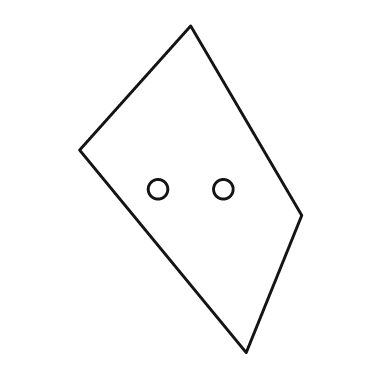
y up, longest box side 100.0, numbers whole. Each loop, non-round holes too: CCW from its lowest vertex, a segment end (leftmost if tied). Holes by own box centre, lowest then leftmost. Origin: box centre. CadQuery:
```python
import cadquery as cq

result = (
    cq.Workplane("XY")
    .moveTo(17.0, -50.0)
    .lineTo(34.0, -8.0)
    .lineTo(0.0, 50.0)
    .lineTo(-34.0, 12.0)
    .close()
    .moveTo(-10.0, 0.0)
    .circle(3.0)
    .moveTo(10.0, 0.0)
    .circle(3.0)
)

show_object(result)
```